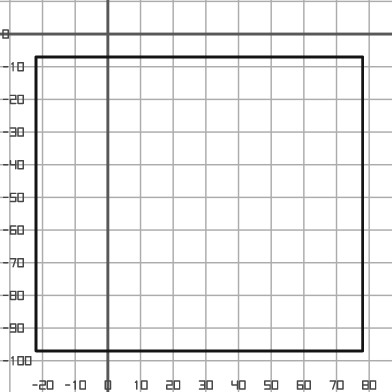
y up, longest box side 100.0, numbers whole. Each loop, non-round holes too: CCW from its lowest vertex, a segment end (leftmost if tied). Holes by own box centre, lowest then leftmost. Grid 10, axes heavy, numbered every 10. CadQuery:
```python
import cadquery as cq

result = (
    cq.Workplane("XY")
    .moveTo(-22.0, -97.0)
    .lineTo(78.0, -97.0)
    .lineTo(78.0, -7.0)
    .lineTo(-22.0, -7.0)
    .close()
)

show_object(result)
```